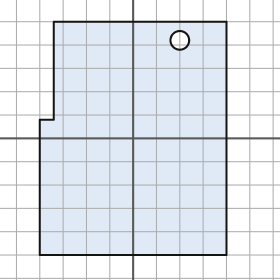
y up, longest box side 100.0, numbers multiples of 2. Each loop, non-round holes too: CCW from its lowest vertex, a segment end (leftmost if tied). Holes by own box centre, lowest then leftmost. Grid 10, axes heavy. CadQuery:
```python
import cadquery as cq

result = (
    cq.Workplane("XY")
    .moveTo(-40.0, -50.0)
    .lineTo(40.0, -50.0)
    .lineTo(40.0, 50.0)
    .lineTo(-34.0, 50.0)
    .lineTo(-34.0, 8.0)
    .lineTo(-40.0, 8.0)
    .close()
    .moveTo(20.0, 42.0)
    .circle(4.0)
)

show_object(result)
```